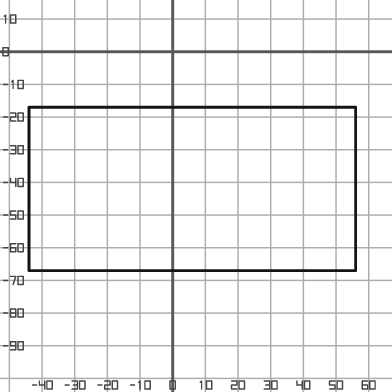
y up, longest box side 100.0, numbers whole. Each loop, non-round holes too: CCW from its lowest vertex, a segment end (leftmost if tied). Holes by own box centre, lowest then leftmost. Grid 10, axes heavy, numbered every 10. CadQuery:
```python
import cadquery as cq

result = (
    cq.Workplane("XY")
    .moveTo(-44.0, -67.0)
    .lineTo(56.0, -67.0)
    .lineTo(56.0, -17.0)
    .lineTo(-44.0, -17.0)
    .close()
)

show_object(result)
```